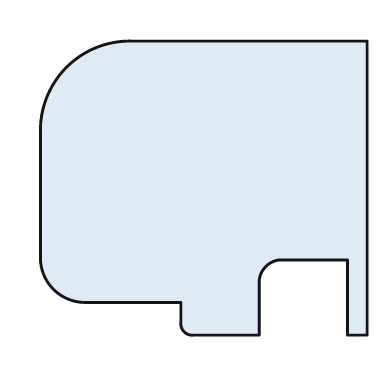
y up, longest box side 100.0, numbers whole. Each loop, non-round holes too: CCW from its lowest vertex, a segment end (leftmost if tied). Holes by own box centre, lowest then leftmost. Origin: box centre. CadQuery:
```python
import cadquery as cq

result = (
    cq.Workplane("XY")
    .moveTo(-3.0, -45.0)
    .lineTo(17.0, -45.0)
    .lineTo(17.0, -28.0)
    .threePointArc((19.0, -24.0), (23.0, -22.0))
    .lineTo(44.0, -22.0)
    .lineTo(44.0, -45.0)
    .lineTo(50.0, -45.0)
    .lineTo(50.0, 45.0)
    .lineTo(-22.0, 45.0)
    .threePointArc((-42.0, 37.0), (-50.0, 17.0))
    .lineTo(-50.0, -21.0)
    .threePointArc((-46.0, -31.0), (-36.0, -35.0))
    .lineTo(-7.0, -35.0)
    .lineTo(-7.0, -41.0)
    .threePointArc((-6.0, -44.0), (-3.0, -45.0))
    .close()
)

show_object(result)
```